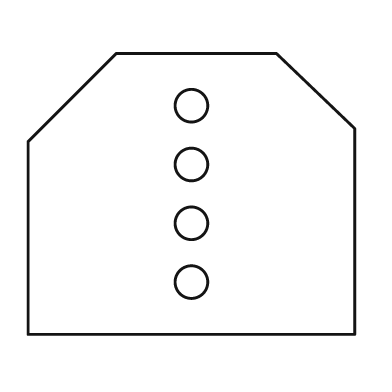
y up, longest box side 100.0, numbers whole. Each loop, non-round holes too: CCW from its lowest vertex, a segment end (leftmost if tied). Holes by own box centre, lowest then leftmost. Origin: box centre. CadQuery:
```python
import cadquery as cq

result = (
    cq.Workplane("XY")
    .moveTo(-50.0, -43.0)
    .lineTo(50.0, -43.0)
    .lineTo(50.0, 20.0)
    .lineTo(26.0, 43.0)
    .lineTo(-23.0, 43.0)
    .lineTo(-50.0, 16.0)
    .close()
    .moveTo(0.0, -27.0)
    .circle(5.0)
    .moveTo(0.0, -9.0)
    .circle(5.0)
    .moveTo(0.0, 9.0)
    .circle(5.0)
    .moveTo(0.0, 27.0)
    .circle(5.0)
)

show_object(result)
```